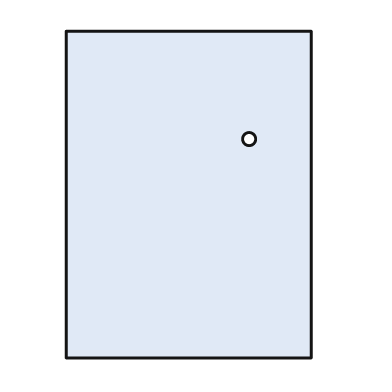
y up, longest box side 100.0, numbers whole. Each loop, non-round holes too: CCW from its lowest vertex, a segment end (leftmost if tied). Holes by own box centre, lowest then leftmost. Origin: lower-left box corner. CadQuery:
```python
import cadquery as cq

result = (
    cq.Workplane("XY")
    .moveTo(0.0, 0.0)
    .lineTo(75.0, 0.0)
    .lineTo(75.0, 100.0)
    .lineTo(0.0, 100.0)
    .close()
    .moveTo(56.0, 67.0)
    .circle(2.0)
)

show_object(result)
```